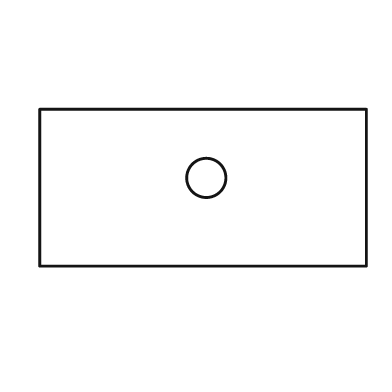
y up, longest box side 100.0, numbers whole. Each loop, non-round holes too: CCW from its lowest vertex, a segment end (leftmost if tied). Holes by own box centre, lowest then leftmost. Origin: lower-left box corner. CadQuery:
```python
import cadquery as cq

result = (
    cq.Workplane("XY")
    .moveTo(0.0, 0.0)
    .lineTo(100.0, 0.0)
    .lineTo(100.0, 48.0)
    .lineTo(0.0, 48.0)
    .close()
    .moveTo(51.0, 27.0)
    .circle(6.0)
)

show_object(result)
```